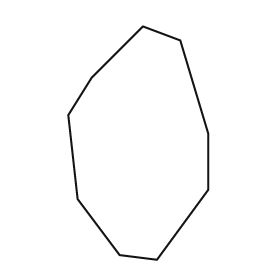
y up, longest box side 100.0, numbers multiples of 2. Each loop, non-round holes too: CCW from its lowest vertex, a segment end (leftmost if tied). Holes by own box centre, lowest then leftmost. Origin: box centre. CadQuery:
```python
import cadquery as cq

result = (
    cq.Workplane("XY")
    .moveTo(8.0, -50.0)
    .lineTo(30.0, -20.0)
    .lineTo(30.0, 4.0)
    .lineTo(18.0, 44.0)
    .lineTo(2.0, 50.0)
    .lineTo(-20.0, 28.0)
    .lineTo(-30.0, 12.0)
    .lineTo(-26.0, -24.0)
    .lineTo(-8.0, -48.0)
    .close()
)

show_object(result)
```